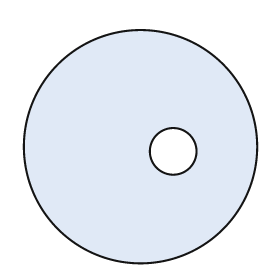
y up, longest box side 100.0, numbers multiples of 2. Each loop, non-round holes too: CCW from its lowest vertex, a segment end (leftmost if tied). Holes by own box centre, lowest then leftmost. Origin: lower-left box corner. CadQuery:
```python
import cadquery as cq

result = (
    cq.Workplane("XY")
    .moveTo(50.0, 50.0)
    .circle(50.0)
    .moveTo(64.0, 48.0)
    .circle(10.0)
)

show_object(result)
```